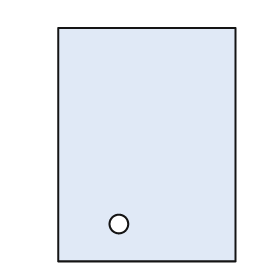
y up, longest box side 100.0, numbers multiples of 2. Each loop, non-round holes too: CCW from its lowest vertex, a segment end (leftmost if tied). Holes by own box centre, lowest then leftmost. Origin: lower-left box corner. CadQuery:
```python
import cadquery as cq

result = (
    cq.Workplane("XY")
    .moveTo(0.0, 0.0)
    .lineTo(76.0, 0.0)
    .lineTo(76.0, 100.0)
    .lineTo(0.0, 100.0)
    .close()
    .moveTo(26.0, 16.0)
    .circle(4.0)
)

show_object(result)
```